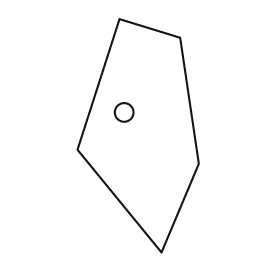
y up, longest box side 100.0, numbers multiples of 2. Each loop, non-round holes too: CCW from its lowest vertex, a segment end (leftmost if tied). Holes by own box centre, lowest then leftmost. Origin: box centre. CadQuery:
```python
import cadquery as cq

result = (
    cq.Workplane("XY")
    .moveTo(10.0, -50.0)
    .lineTo(26.0, -12.0)
    .lineTo(18.0, 42.0)
    .lineTo(-8.0, 50.0)
    .lineTo(-26.0, -6.0)
    .close()
    .moveTo(-6.0, 10.0)
    .circle(4.0)
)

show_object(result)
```